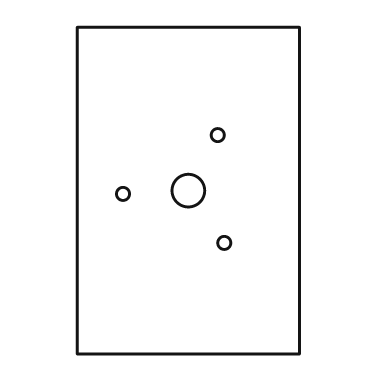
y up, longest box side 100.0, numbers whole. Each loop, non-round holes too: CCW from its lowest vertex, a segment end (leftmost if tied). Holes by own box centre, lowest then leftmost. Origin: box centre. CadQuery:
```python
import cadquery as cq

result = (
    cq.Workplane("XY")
    .moveTo(-34.0, -50.0)
    .lineTo(34.0, -50.0)
    .lineTo(34.0, 50.0)
    .lineTo(-34.0, 50.0)
    .close()
    .moveTo(11.0, -16.0)
    .circle(2.0)
    .moveTo(-20.0, -1.0)
    .circle(2.0)
    .moveTo(0.0, 0.0)
    .circle(5.0)
    .moveTo(9.0, 17.0)
    .circle(2.0)
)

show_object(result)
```